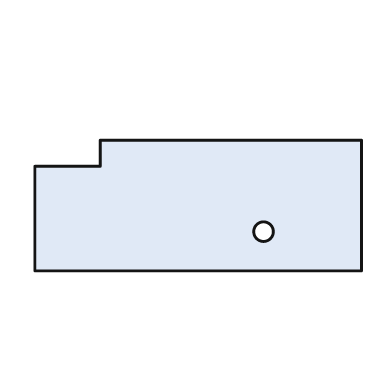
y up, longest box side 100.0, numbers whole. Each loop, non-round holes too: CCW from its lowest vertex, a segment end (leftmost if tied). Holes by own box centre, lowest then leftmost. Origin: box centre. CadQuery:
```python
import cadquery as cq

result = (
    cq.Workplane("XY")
    .moveTo(-50.0, -20.0)
    .lineTo(50.0, -20.0)
    .lineTo(50.0, 20.0)
    .lineTo(-30.0, 20.0)
    .lineTo(-30.0, 12.0)
    .lineTo(-50.0, 12.0)
    .close()
    .moveTo(20.0, -8.0)
    .circle(3.0)
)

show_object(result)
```